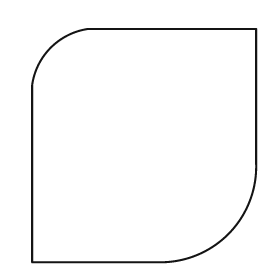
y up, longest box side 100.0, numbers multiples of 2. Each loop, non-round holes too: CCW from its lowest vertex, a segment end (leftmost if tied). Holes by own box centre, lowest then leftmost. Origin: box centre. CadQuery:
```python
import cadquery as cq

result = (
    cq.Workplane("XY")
    .moveTo(-48.0, -50.0)
    .lineTo(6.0, -50.0)
    .threePointArc((36.0, -38.0), (48.0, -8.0))
    .lineTo(48.0, 50.0)
    .lineTo(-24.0, 50.0)
    .threePointArc((-40.0, 42.0), (-48.0, 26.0))
    .close()
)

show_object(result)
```